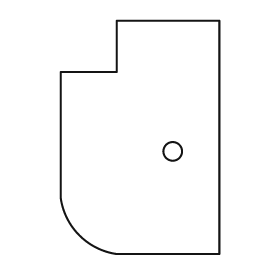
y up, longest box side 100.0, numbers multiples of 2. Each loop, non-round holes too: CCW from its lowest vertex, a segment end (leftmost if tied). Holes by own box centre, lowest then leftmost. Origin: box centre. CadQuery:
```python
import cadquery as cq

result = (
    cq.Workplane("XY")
    .moveTo(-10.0, -50.0)
    .lineTo(34.0, -50.0)
    .lineTo(34.0, 50.0)
    .lineTo(-10.0, 50.0)
    .lineTo(-10.0, 28.0)
    .lineTo(-34.0, 28.0)
    .lineTo(-34.0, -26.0)
    .threePointArc((-26.0, -42.0), (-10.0, -50.0))
    .close()
    .moveTo(14.0, -6.0)
    .circle(4.0)
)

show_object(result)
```